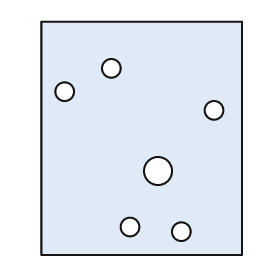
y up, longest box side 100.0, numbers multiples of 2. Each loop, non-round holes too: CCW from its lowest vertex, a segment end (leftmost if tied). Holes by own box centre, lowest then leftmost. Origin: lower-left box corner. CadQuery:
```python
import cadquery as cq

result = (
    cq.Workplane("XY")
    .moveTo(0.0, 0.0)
    .lineTo(86.0, 0.0)
    .lineTo(86.0, 100.0)
    .lineTo(0.0, 100.0)
    .close()
    .moveTo(60.0, 10.0)
    .circle(4.0)
    .moveTo(38.0, 12.0)
    .circle(4.0)
    .moveTo(50.0, 36.0)
    .circle(6.0)
    .moveTo(74.0, 62.0)
    .circle(4.0)
    .moveTo(10.0, 70.0)
    .circle(4.0)
    .moveTo(30.0, 80.0)
    .circle(4.0)
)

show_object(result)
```